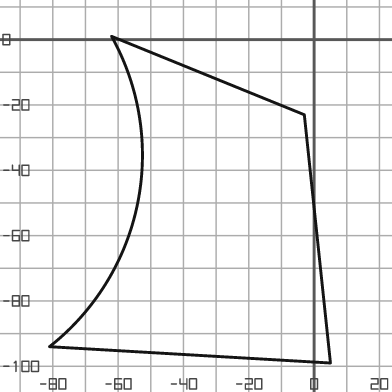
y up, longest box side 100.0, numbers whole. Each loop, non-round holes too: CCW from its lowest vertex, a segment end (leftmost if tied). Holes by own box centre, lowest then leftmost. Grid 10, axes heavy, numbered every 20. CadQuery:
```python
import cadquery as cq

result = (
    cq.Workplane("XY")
    .moveTo(5.0, -99.0)
    .lineTo(-3.0, -23.0)
    .lineTo(-62.0, 1.0)
    .threePointArc((-54.0, -50.0), (-81.0, -94.0))
    .close()
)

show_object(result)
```